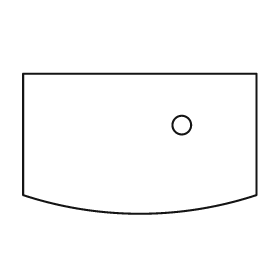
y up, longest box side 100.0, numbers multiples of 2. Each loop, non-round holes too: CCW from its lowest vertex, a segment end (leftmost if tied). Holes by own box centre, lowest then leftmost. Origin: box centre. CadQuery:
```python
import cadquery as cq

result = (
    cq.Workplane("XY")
    .moveTo(-50.0, -22.0)
    .threePointArc((0.0, -30.0), (50.0, -22.0))
    .lineTo(50.0, 30.0)
    .lineTo(-50.0, 30.0)
    .close()
    .moveTo(18.0, 8.0)
    .circle(4.0)
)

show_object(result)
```